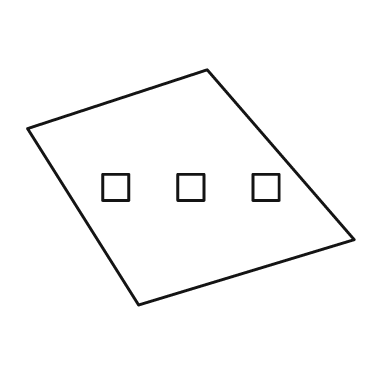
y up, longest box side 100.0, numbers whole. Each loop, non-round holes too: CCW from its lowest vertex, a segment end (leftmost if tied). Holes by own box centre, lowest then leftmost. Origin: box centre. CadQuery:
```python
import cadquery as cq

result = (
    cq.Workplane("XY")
    .moveTo(-16.0, -36.0)
    .lineTo(50.0, -16.0)
    .lineTo(5.0, 36.0)
    .lineTo(-50.0, 18.0)
    .close()
    .moveTo(-27.0, -4.0)
    .lineTo(-19.0, -4.0)
    .lineTo(-19.0, 4.0)
    .lineTo(-27.0, 4.0)
    .close()
    .moveTo(-4.0, -4.0)
    .lineTo(4.0, -4.0)
    .lineTo(4.0, 4.0)
    .lineTo(-4.0, 4.0)
    .close()
    .moveTo(19.0, -4.0)
    .lineTo(27.0, -4.0)
    .lineTo(27.0, 4.0)
    .lineTo(19.0, 4.0)
    .close()
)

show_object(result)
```